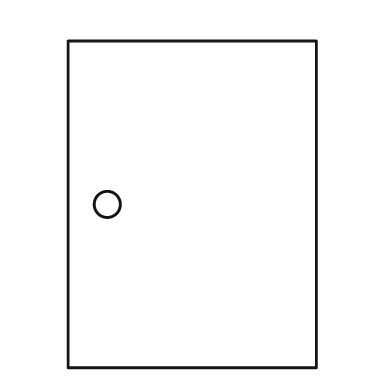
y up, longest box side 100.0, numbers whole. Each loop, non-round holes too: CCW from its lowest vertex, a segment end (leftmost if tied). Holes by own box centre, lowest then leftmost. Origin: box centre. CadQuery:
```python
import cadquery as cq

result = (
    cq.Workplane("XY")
    .moveTo(-38.0, -50.0)
    .lineTo(38.0, -50.0)
    .lineTo(38.0, 50.0)
    .lineTo(-38.0, 50.0)
    .close()
    .moveTo(-26.0, 0.0)
    .circle(4.0)
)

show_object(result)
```